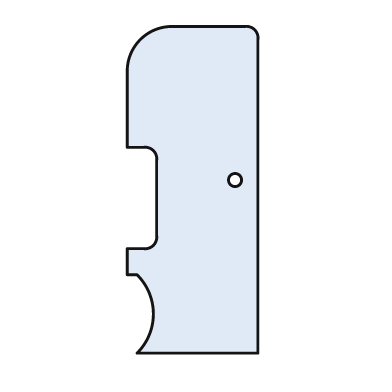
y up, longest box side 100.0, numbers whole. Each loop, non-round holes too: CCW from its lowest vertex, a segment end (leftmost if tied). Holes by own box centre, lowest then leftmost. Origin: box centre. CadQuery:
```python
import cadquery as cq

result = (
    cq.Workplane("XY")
    .moveTo(-17.0, -50.0)
    .lineTo(20.0, -50.0)
    .lineTo(20.0, 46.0)
    .threePointArc((19.0, 49.0), (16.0, 50.0))
    .lineTo(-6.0, 50.0)
    .threePointArc((-16.0, 46.0), (-20.0, 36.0))
    .lineTo(-20.0, 13.0)
    .lineTo(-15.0, 13.0)
    .threePointArc((-12.0, 12.0), (-11.0, 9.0))
    .lineTo(-11.0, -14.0)
    .threePointArc((-12.0, -17.0), (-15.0, -18.0))
    .lineTo(-20.0, -18.0)
    .lineTo(-20.0, -26.0)
    .lineTo(-17.0, -26.0)
    .threePointArc((-12.0, -38.0), (-17.0, -50.0))
    .close()
    .moveTo(13.0, 3.0)
    .circle(2.0)
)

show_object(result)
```